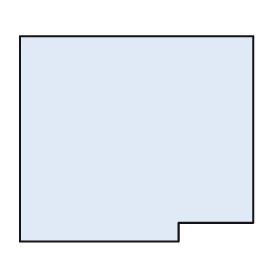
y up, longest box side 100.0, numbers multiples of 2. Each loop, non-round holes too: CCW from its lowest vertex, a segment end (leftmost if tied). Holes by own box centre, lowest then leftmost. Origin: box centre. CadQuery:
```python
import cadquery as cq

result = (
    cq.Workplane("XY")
    .moveTo(-50.0, -44.0)
    .lineTo(18.0, -44.0)
    .lineTo(18.0, -36.0)
    .lineTo(50.0, -36.0)
    .lineTo(50.0, 44.0)
    .lineTo(-50.0, 44.0)
    .close()
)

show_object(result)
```